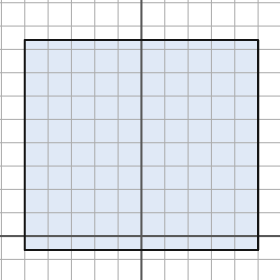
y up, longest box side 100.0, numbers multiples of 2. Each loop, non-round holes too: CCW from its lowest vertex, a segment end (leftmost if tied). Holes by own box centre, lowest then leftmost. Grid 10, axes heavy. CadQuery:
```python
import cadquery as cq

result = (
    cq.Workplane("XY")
    .moveTo(-50.0, -6.0)
    .lineTo(50.0, -6.0)
    .lineTo(50.0, 84.0)
    .lineTo(-50.0, 84.0)
    .close()
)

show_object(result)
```